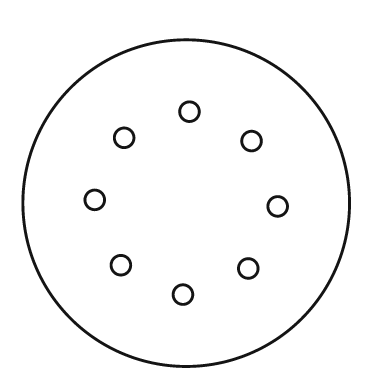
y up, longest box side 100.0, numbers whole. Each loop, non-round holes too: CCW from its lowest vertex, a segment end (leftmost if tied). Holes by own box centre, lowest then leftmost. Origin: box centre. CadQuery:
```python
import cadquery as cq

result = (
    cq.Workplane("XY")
    .moveTo(0.0, 0.0)
    .circle(50.0)
    .moveTo(-1.0, -28.0)
    .circle(3.0)
    .moveTo(19.0, -20.0)
    .circle(3.0)
    .moveTo(-20.0, -19.0)
    .circle(3.0)
    .moveTo(28.0, -1.0)
    .circle(3.0)
    .moveTo(-28.0, 1.0)
    .circle(3.0)
    .moveTo(20.0, 19.0)
    .circle(3.0)
    .moveTo(-19.0, 20.0)
    .circle(3.0)
    .moveTo(1.0, 28.0)
    .circle(3.0)
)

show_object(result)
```